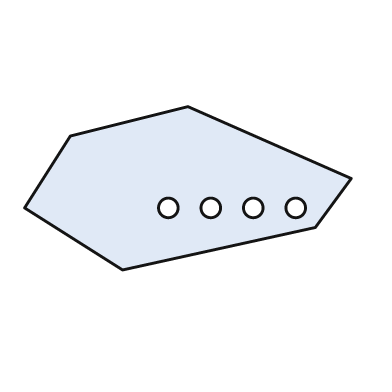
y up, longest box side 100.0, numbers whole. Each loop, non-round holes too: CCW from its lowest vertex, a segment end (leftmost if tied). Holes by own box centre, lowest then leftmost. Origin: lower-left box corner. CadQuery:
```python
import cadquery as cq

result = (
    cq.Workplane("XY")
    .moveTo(30.0, 0.0)
    .lineTo(89.0, 13.0)
    .lineTo(100.0, 28.0)
    .lineTo(50.0, 50.0)
    .lineTo(14.0, 41.0)
    .lineTo(0.0, 19.0)
    .close()
    .moveTo(44.0, 19.0)
    .circle(3.0)
    .moveTo(57.0, 19.0)
    .circle(3.0)
    .moveTo(70.0, 19.0)
    .circle(3.0)
    .moveTo(83.0, 19.0)
    .circle(3.0)
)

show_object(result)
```